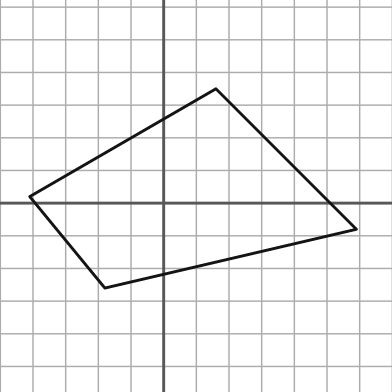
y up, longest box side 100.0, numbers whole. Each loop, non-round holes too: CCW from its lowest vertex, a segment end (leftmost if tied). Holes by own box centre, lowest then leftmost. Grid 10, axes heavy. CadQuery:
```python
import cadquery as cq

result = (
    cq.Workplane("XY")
    .moveTo(-18.0, -26.0)
    .lineTo(59.0, -8.0)
    .lineTo(16.0, 35.0)
    .lineTo(-41.0, 2.0)
    .close()
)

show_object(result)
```